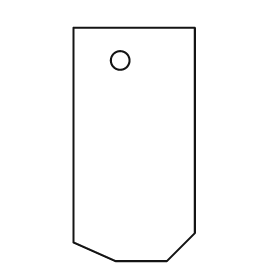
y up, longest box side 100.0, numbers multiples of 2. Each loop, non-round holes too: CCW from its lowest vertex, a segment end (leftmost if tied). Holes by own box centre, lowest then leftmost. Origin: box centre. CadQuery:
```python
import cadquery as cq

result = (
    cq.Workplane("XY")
    .moveTo(-8.0, -50.0)
    .lineTo(14.0, -50.0)
    .lineTo(26.0, -38.0)
    .lineTo(26.0, 50.0)
    .lineTo(-26.0, 50.0)
    .lineTo(-26.0, -42.0)
    .close()
    .moveTo(-6.0, 36.0)
    .circle(4.0)
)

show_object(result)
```